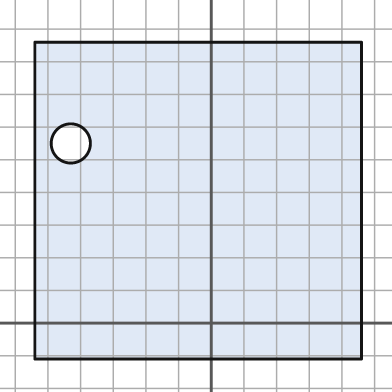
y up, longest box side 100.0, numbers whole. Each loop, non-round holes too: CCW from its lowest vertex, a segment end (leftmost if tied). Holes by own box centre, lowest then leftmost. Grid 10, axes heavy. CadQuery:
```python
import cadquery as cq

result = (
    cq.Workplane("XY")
    .moveTo(-54.0, -11.0)
    .lineTo(46.0, -11.0)
    .lineTo(46.0, 86.0)
    .lineTo(-54.0, 86.0)
    .close()
    .moveTo(-43.0, 55.0)
    .circle(6.0)
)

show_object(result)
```